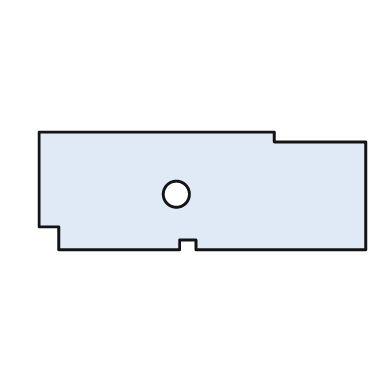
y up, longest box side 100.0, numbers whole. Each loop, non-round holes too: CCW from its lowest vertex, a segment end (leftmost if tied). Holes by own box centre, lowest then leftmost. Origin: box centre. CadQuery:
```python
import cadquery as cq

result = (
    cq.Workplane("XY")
    .moveTo(-44.0, -18.0)
    .lineTo(-7.0, -18.0)
    .lineTo(-7.0, -15.0)
    .lineTo(-2.0, -15.0)
    .lineTo(-2.0, -18.0)
    .lineTo(50.0, -18.0)
    .lineTo(50.0, 15.0)
    .lineTo(22.0, 15.0)
    .lineTo(22.0, 18.0)
    .lineTo(-50.0, 18.0)
    .lineTo(-50.0, -11.0)
    .lineTo(-44.0, -11.0)
    .close()
    .moveTo(-8.0, -1.0)
    .circle(4.0)
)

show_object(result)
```